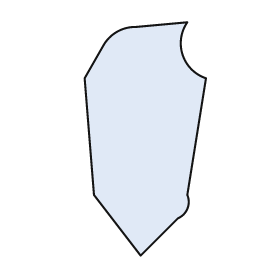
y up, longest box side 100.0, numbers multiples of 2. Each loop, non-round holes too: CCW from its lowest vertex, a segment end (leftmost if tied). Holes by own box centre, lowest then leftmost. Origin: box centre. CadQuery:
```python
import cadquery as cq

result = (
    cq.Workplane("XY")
    .moveTo(-2.0, -50.0)
    .lineTo(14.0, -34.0)
    .threePointArc((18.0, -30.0), (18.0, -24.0))
    .lineTo(26.0, 26.0)
    .threePointArc((16.0, 36.0), (18.0, 50.0))
    .lineTo(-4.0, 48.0)
    .threePointArc((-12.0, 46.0), (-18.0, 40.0))
    .lineTo(-26.0, 26.0)
    .lineTo(-22.0, -24.0)
    .close()
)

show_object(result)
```